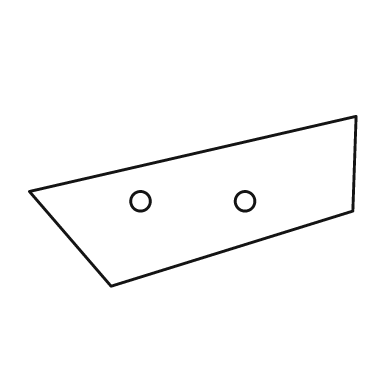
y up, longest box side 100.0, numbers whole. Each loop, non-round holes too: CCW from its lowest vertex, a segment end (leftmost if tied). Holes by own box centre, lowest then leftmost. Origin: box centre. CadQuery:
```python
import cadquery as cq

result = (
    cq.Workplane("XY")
    .moveTo(-25.0, -26.0)
    .lineTo(49.0, -3.0)
    .lineTo(50.0, 26.0)
    .lineTo(-50.0, 3.0)
    .close()
    .moveTo(-16.0, 0.0)
    .circle(3.0)
    .moveTo(16.0, 0.0)
    .circle(3.0)
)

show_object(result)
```